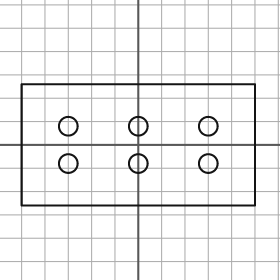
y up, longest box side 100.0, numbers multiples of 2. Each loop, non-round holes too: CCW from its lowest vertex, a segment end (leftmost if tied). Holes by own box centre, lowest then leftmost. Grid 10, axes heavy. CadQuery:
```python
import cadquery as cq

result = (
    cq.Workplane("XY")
    .moveTo(-50.0, -26.0)
    .lineTo(50.0, -26.0)
    .lineTo(50.0, 26.0)
    .lineTo(-50.0, 26.0)
    .close()
    .moveTo(-30.0, -8.0)
    .circle(4.0)
    .moveTo(0.0, -8.0)
    .circle(4.0)
    .moveTo(30.0, -8.0)
    .circle(4.0)
    .moveTo(-30.0, 8.0)
    .circle(4.0)
    .moveTo(0.0, 8.0)
    .circle(4.0)
    .moveTo(30.0, 8.0)
    .circle(4.0)
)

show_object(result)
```